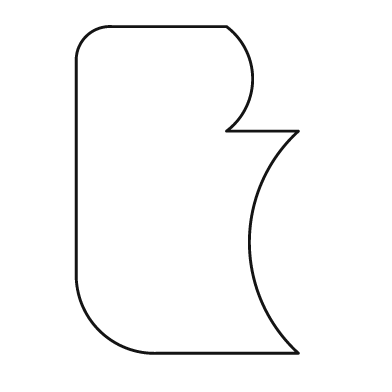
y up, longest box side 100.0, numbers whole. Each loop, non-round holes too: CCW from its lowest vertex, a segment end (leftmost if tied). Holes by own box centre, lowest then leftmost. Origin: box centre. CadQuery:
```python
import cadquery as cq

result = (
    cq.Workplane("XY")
    .moveTo(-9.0, -50.0)
    .lineTo(34.0, -50.0)
    .threePointArc((19.0, -16.0), (34.0, 18.0))
    .lineTo(12.0, 18.0)
    .threePointArc((20.0, 34.0), (12.0, 50.0))
    .lineTo(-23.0, 50.0)
    .threePointArc((-31.0, 47.0), (-34.0, 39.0))
    .lineTo(-34.0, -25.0)
    .threePointArc((-27.0, -43.0), (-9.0, -50.0))
    .close()
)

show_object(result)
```